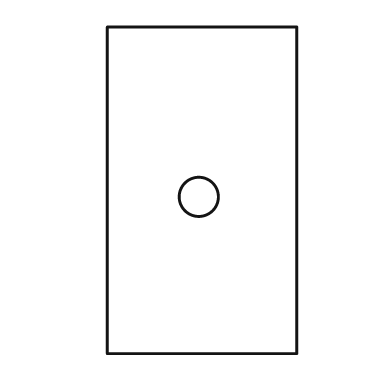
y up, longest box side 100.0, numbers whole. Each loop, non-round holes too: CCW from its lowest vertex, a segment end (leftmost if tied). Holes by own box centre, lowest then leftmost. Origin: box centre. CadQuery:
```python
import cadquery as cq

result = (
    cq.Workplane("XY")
    .moveTo(-29.0, -50.0)
    .lineTo(29.0, -50.0)
    .lineTo(29.0, 50.0)
    .lineTo(-29.0, 50.0)
    .close()
    .moveTo(-1.0, -2.0)
    .circle(6.0)
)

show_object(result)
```